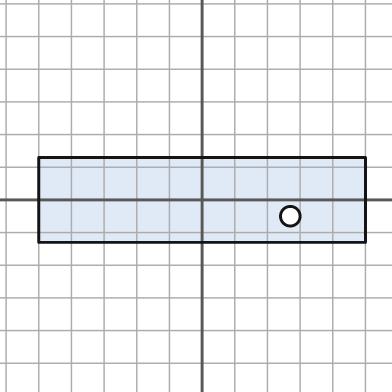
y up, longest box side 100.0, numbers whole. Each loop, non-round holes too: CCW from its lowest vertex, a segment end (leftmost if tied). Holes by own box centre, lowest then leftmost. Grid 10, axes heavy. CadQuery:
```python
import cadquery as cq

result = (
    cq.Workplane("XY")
    .moveTo(-50.0, -13.0)
    .lineTo(50.0, -13.0)
    .lineTo(50.0, 13.0)
    .lineTo(-50.0, 13.0)
    .close()
    .moveTo(27.0, -5.0)
    .circle(3.0)
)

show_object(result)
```